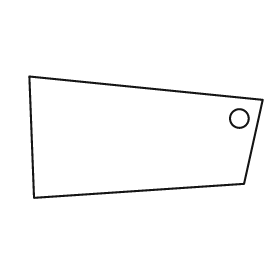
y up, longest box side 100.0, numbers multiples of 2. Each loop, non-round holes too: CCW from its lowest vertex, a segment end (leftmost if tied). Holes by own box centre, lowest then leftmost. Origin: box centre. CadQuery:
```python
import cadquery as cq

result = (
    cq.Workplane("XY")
    .moveTo(-48.0, -26.0)
    .lineTo(42.0, -20.0)
    .lineTo(50.0, 16.0)
    .lineTo(-50.0, 26.0)
    .close()
    .moveTo(40.0, 8.0)
    .circle(4.0)
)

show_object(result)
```